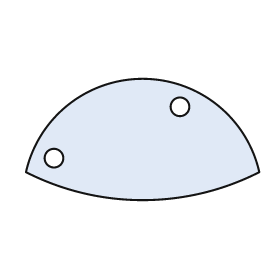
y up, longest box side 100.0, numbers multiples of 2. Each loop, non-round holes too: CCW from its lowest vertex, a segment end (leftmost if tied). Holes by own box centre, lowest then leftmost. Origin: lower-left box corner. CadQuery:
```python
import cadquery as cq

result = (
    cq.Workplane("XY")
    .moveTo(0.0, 12.0)
    .threePointArc((50.0, 0.0), (100.0, 12.0))
    .threePointArc((50.0, 52.0), (0.0, 12.0))
    .close()
    .moveTo(12.0, 18.0)
    .circle(4.0)
    .moveTo(66.0, 40.0)
    .circle(4.0)
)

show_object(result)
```